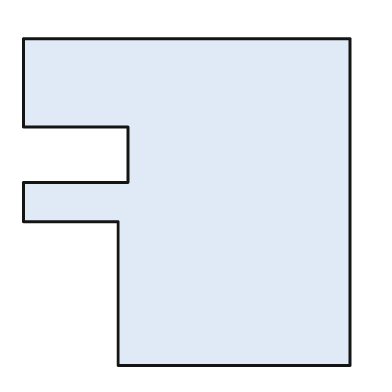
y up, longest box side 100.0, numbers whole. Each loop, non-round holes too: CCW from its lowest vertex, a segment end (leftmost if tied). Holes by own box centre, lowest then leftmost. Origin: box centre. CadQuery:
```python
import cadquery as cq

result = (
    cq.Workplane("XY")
    .moveTo(-21.0, -50.0)
    .lineTo(50.0, -50.0)
    .lineTo(50.0, 50.0)
    .lineTo(-50.0, 50.0)
    .lineTo(-50.0, 23.0)
    .lineTo(-18.0, 23.0)
    .lineTo(-18.0, 6.0)
    .lineTo(-50.0, 6.0)
    .lineTo(-50.0, -6.0)
    .lineTo(-21.0, -6.0)
    .close()
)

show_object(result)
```